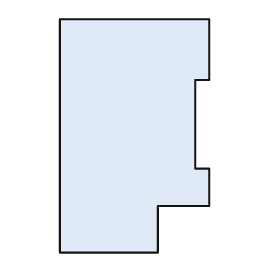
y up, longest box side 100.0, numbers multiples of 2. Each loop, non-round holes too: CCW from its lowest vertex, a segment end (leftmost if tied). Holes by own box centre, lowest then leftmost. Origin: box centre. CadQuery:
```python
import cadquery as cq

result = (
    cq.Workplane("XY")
    .moveTo(-32.0, -50.0)
    .lineTo(10.0, -50.0)
    .lineTo(10.0, -30.0)
    .lineTo(32.0, -30.0)
    .lineTo(32.0, -14.0)
    .lineTo(26.0, -14.0)
    .lineTo(26.0, 24.0)
    .lineTo(32.0, 24.0)
    .lineTo(32.0, 50.0)
    .lineTo(-32.0, 50.0)
    .close()
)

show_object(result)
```